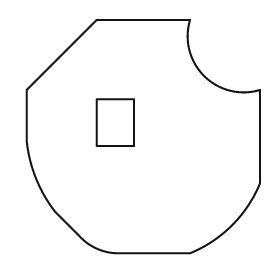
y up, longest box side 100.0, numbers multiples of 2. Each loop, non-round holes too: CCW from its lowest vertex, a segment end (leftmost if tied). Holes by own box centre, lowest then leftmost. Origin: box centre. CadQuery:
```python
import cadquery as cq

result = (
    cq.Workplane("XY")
    .moveTo(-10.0, -50.0)
    .lineTo(20.0, -50.0)
    .threePointArc((38.0, -38.0), (50.0, -20.0))
    .lineTo(50.0, 20.0)
    .threePointArc((26.0, 26.0), (20.0, 50.0))
    .lineTo(-20.0, 50.0)
    .lineTo(-50.0, 20.0)
    .lineTo(-50.0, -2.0)
    .threePointArc((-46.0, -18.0), (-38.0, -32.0))
    .lineTo(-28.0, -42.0)
    .threePointArc((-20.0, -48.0), (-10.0, -50.0))
    .close()
    .moveTo(-20.0, -4.0)
    .lineTo(-4.0, -4.0)
    .lineTo(-4.0, 16.0)
    .lineTo(-20.0, 16.0)
    .close()
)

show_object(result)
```